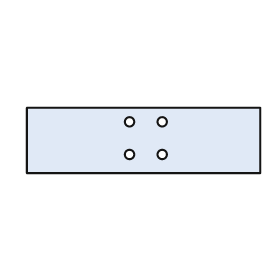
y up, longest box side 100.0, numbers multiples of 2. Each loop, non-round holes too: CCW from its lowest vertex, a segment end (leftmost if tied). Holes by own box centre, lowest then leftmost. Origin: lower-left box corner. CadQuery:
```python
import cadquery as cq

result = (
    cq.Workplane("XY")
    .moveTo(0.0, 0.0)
    .lineTo(100.0, 0.0)
    .lineTo(100.0, 28.0)
    .lineTo(0.0, 28.0)
    .close()
    .moveTo(44.0, 8.0)
    .circle(2.0)
    .moveTo(58.0, 8.0)
    .circle(2.0)
    .moveTo(44.0, 22.0)
    .circle(2.0)
    .moveTo(58.0, 22.0)
    .circle(2.0)
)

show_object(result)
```